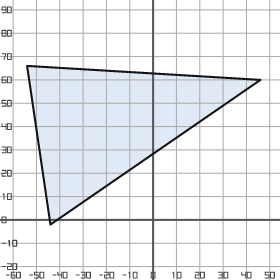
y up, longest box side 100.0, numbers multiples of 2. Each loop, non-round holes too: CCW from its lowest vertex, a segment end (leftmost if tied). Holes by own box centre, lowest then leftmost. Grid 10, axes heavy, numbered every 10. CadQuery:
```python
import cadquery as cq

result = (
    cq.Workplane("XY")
    .moveTo(-44.0, -2.0)
    .lineTo(46.0, 60.0)
    .lineTo(-54.0, 66.0)
    .close()
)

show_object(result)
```